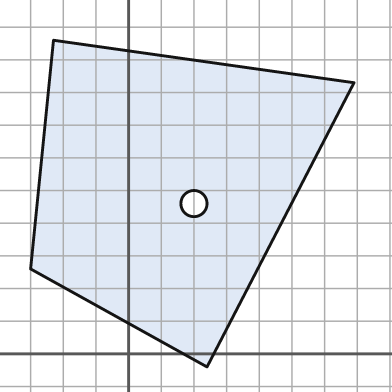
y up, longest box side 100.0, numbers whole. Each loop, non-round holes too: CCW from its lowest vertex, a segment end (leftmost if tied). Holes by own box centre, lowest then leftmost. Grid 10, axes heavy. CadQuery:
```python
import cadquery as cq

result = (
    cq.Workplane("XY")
    .moveTo(24.0, -4.0)
    .lineTo(69.0, 83.0)
    .lineTo(-23.0, 96.0)
    .lineTo(-30.0, 26.0)
    .close()
    .moveTo(20.0, 46.0)
    .circle(4.0)
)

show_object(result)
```